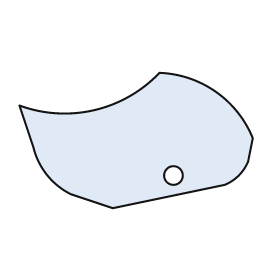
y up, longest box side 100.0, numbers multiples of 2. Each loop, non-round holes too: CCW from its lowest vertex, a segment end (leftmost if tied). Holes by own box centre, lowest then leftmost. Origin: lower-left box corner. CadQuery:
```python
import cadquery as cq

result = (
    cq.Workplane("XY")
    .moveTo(40.0, 0.0)
    .lineTo(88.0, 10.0)
    .threePointArc((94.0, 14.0), (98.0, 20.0))
    .lineTo(100.0, 30.0)
    .threePointArc((84.0, 50.0), (60.0, 58.0))
    .threePointArc((32.0, 42.0), (0.0, 44.0))
    .lineTo(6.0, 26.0)
    .threePointArc((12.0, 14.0), (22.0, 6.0))
    .close()
    .moveTo(66.0, 14.0)
    .circle(4.0)
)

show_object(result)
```